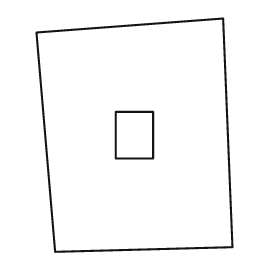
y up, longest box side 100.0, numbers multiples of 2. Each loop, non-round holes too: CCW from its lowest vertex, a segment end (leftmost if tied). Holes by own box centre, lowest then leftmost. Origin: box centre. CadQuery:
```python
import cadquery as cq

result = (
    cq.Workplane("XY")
    .moveTo(-34.0, -50.0)
    .lineTo(42.0, -48.0)
    .lineTo(38.0, 50.0)
    .lineTo(-42.0, 44.0)
    .close()
    .moveTo(-8.0, -10.0)
    .lineTo(8.0, -10.0)
    .lineTo(8.0, 10.0)
    .lineTo(-8.0, 10.0)
    .close()
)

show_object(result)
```